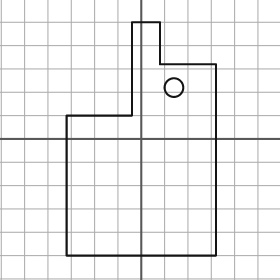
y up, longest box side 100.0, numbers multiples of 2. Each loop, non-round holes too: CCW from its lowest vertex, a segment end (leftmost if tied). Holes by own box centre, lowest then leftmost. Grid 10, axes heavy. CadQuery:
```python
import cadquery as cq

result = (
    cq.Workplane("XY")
    .moveTo(-32.0, -50.0)
    .lineTo(32.0, -50.0)
    .lineTo(32.0, 32.0)
    .lineTo(8.0, 32.0)
    .lineTo(8.0, 50.0)
    .lineTo(-4.0, 50.0)
    .lineTo(-4.0, 10.0)
    .lineTo(-32.0, 10.0)
    .close()
    .moveTo(14.0, 22.0)
    .circle(4.0)
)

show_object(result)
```